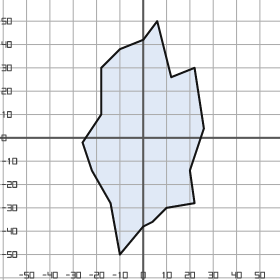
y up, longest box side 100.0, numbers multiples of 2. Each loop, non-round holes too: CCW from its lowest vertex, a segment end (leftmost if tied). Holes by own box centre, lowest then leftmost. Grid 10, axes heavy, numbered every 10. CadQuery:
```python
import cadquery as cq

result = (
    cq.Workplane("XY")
    .moveTo(-10.0, -50.0)
    .lineTo(0.0, -38.0)
    .lineTo(4.0, -36.0)
    .lineTo(10.0, -30.0)
    .lineTo(22.0, -28.0)
    .lineTo(20.0, -14.0)
    .lineTo(26.0, 4.0)
    .lineTo(22.0, 30.0)
    .lineTo(12.0, 26.0)
    .lineTo(6.0, 50.0)
    .lineTo(0.0, 42.0)
    .lineTo(-10.0, 38.0)
    .lineTo(-18.0, 30.0)
    .lineTo(-18.0, 10.0)
    .lineTo(-26.0, -2.0)
    .lineTo(-22.0, -14.0)
    .lineTo(-14.0, -28.0)
    .close()
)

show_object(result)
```